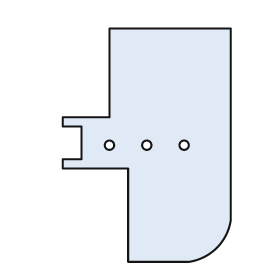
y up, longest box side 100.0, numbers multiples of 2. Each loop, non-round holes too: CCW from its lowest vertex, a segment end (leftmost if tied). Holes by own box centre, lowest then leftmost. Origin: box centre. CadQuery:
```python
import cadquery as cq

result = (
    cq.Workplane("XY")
    .moveTo(-8.0, -50.0)
    .lineTo(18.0, -50.0)
    .threePointArc((30.0, -44.0), (36.0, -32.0))
    .lineTo(36.0, 50.0)
    .lineTo(-16.0, 50.0)
    .lineTo(-16.0, 12.0)
    .lineTo(-36.0, 12.0)
    .lineTo(-36.0, 8.0)
    .lineTo(-28.0, 8.0)
    .lineTo(-28.0, -6.0)
    .lineTo(-36.0, -6.0)
    .lineTo(-36.0, -10.0)
    .lineTo(-8.0, -10.0)
    .close()
    .moveTo(-16.0, 0.0)
    .circle(2.0)
    .moveTo(0.0, 0.0)
    .circle(2.0)
    .moveTo(16.0, 0.0)
    .circle(2.0)
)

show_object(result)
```